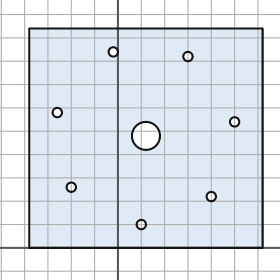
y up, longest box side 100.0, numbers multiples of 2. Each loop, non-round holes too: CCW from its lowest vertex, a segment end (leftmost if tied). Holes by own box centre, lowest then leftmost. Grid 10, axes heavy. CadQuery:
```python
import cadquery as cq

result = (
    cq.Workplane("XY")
    .moveTo(-38.0, 0.0)
    .lineTo(62.0, 0.0)
    .lineTo(62.0, 94.0)
    .lineTo(-38.0, 94.0)
    .close()
    .moveTo(10.0, 10.0)
    .circle(2.0)
    .moveTo(40.0, 22.0)
    .circle(2.0)
    .moveTo(-20.0, 26.0)
    .circle(2.0)
    .moveTo(12.0, 48.0)
    .circle(6.0)
    .moveTo(50.0, 54.0)
    .circle(2.0)
    .moveTo(-26.0, 58.0)
    .circle(2.0)
    .moveTo(30.0, 82.0)
    .circle(2.0)
    .moveTo(-2.0, 84.0)
    .circle(2.0)
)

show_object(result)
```